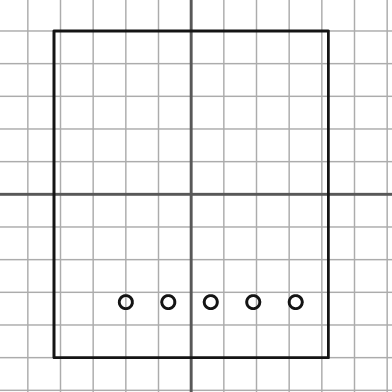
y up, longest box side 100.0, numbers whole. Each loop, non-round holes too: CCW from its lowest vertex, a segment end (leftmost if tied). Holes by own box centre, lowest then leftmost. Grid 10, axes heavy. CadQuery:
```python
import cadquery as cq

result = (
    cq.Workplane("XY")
    .moveTo(-42.0, -50.0)
    .lineTo(42.0, -50.0)
    .lineTo(42.0, 50.0)
    .lineTo(-42.0, 50.0)
    .close()
    .moveTo(-20.0, -33.0)
    .circle(2.0)
    .moveTo(-7.0, -33.0)
    .circle(2.0)
    .moveTo(6.0, -33.0)
    .circle(2.0)
    .moveTo(19.0, -33.0)
    .circle(2.0)
    .moveTo(32.0, -33.0)
    .circle(2.0)
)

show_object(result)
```